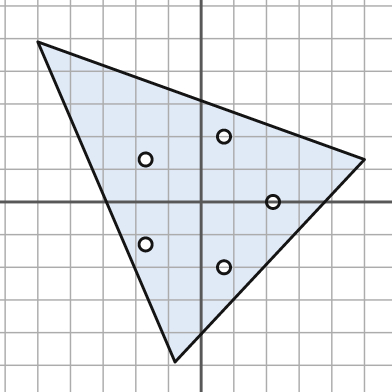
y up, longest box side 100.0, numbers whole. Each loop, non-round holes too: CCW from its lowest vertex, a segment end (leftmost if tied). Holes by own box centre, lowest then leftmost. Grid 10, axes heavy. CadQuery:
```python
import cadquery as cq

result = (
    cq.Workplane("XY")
    .moveTo(-8.0, -49.0)
    .lineTo(50.0, 13.0)
    .lineTo(-50.0, 49.0)
    .close()
    .moveTo(7.0, -20.0)
    .circle(2.0)
    .moveTo(-17.0, -13.0)
    .circle(2.0)
    .moveTo(22.0, 0.0)
    .circle(2.0)
    .moveTo(-17.0, 13.0)
    .circle(2.0)
    .moveTo(7.0, 20.0)
    .circle(2.0)
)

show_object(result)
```